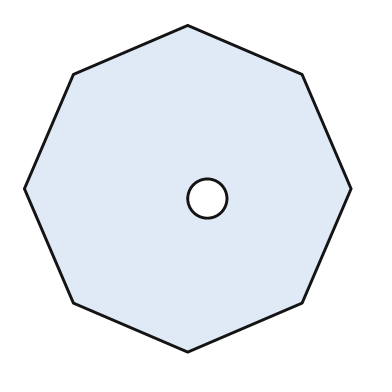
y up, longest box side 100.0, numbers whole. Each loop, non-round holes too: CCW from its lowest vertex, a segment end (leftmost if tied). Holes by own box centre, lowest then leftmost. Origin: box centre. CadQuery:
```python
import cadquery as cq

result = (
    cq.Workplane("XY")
    .moveTo(0.0, -50.0)
    .lineTo(35.0, -35.0)
    .lineTo(50.0, 0.0)
    .lineTo(35.0, 35.0)
    .lineTo(0.0, 50.0)
    .lineTo(-35.0, 35.0)
    .lineTo(-50.0, 0.0)
    .lineTo(-35.0, -35.0)
    .close()
    .moveTo(6.0, -3.0)
    .circle(6.0)
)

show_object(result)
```